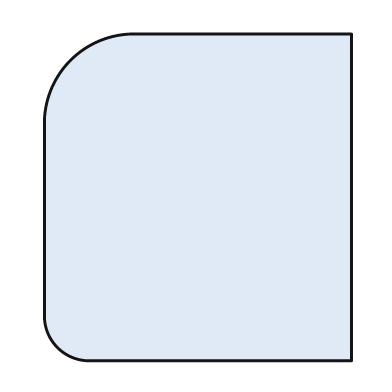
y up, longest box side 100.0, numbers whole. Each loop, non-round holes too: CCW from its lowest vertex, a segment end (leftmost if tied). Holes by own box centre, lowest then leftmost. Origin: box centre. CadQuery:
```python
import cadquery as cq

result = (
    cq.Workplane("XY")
    .moveTo(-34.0, -50.0)
    .lineTo(47.0, -50.0)
    .lineTo(47.0, 50.0)
    .lineTo(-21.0, 50.0)
    .threePointArc((-39.0, 42.0), (-47.0, 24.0))
    .lineTo(-47.0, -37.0)
    .threePointArc((-43.0, -46.0), (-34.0, -50.0))
    .close()
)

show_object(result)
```